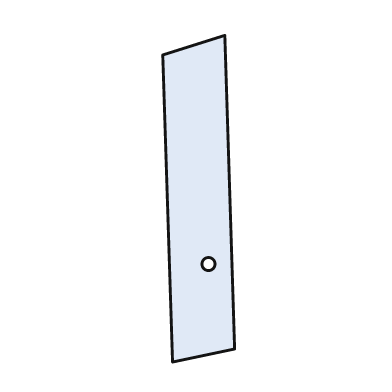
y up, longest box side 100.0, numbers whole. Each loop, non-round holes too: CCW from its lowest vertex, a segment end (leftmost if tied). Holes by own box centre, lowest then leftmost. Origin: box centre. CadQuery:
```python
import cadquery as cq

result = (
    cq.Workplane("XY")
    .moveTo(-8.0, -50.0)
    .lineTo(11.0, -46.0)
    .lineTo(8.0, 50.0)
    .lineTo(-11.0, 44.0)
    .close()
    .moveTo(3.0, -20.0)
    .circle(2.0)
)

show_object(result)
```